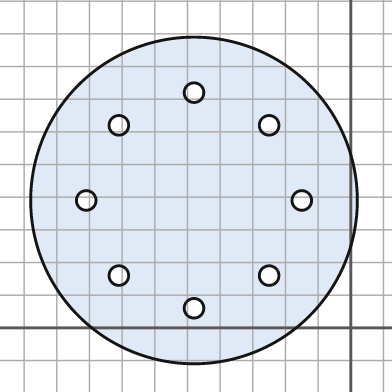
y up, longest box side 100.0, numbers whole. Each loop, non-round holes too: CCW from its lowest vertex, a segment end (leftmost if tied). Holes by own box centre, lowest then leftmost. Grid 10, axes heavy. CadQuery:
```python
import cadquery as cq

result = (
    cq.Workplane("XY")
    .moveTo(-48.0, 39.0)
    .circle(50.0)
    .moveTo(-48.0, 6.0)
    .circle(3.0)
    .moveTo(-71.0, 16.0)
    .circle(3.0)
    .moveTo(-25.0, 16.0)
    .circle(3.0)
    .moveTo(-81.0, 39.0)
    .circle(3.0)
    .moveTo(-15.0, 39.0)
    .circle(3.0)
    .moveTo(-71.0, 62.0)
    .circle(3.0)
    .moveTo(-25.0, 62.0)
    .circle(3.0)
    .moveTo(-48.0, 72.0)
    .circle(3.0)
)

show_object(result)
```